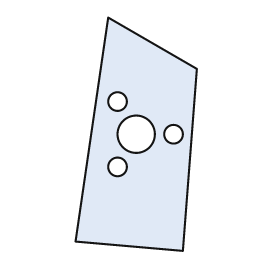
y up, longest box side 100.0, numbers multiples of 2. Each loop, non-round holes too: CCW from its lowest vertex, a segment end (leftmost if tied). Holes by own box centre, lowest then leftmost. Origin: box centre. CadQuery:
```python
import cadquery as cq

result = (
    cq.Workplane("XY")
    .moveTo(20.0, -50.0)
    .lineTo(26.0, 28.0)
    .lineTo(-12.0, 50.0)
    .lineTo(-26.0, -46.0)
    .close()
    .moveTo(-8.0, -14.0)
    .circle(4.0)
    .moveTo(0.0, 0.0)
    .circle(8.0)
    .moveTo(16.0, 0.0)
    .circle(4.0)
    .moveTo(-8.0, 14.0)
    .circle(4.0)
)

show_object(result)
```